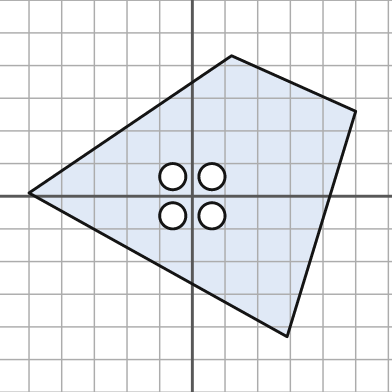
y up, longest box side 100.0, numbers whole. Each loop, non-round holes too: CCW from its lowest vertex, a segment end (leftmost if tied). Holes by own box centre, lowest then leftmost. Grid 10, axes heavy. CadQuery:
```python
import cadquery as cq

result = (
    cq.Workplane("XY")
    .moveTo(29.0, -43.0)
    .lineTo(50.0, 26.0)
    .lineTo(12.0, 43.0)
    .lineTo(-50.0, 1.0)
    .close()
    .moveTo(-6.0, -6.0)
    .circle(4.0)
    .moveTo(6.0, -6.0)
    .circle(4.0)
    .moveTo(-6.0, 6.0)
    .circle(4.0)
    .moveTo(6.0, 6.0)
    .circle(4.0)
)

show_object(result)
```